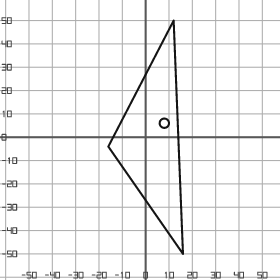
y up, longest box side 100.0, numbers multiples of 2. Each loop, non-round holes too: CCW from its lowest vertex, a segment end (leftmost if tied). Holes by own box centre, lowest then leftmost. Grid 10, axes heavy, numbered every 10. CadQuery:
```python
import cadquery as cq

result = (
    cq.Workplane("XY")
    .moveTo(16.0, -50.0)
    .lineTo(12.0, 50.0)
    .lineTo(-16.0, -4.0)
    .close()
    .moveTo(8.0, 6.0)
    .circle(2.0)
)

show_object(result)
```